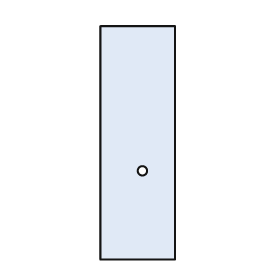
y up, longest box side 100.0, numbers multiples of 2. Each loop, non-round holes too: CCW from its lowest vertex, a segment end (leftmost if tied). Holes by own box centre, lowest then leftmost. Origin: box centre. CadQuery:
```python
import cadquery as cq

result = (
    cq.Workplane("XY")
    .moveTo(-16.0, -50.0)
    .lineTo(16.0, -50.0)
    .lineTo(16.0, 50.0)
    .lineTo(-16.0, 50.0)
    .close()
    .moveTo(2.0, -12.0)
    .circle(2.0)
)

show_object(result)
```